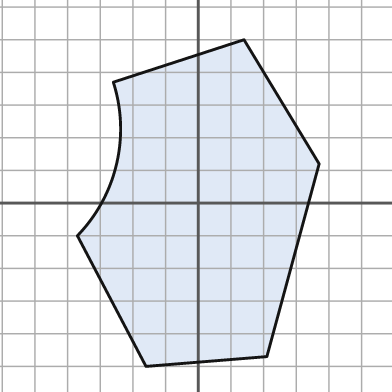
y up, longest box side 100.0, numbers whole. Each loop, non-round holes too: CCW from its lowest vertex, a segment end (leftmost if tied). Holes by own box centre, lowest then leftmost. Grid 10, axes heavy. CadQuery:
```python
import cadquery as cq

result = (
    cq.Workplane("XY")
    .moveTo(-16.0, -50.0)
    .lineTo(21.0, -47.0)
    .lineTo(37.0, 12.0)
    .lineTo(14.0, 50.0)
    .lineTo(-26.0, 37.0)
    .threePointArc((-25.0, 12.0), (-37.0, -10.0))
    .close()
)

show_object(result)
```